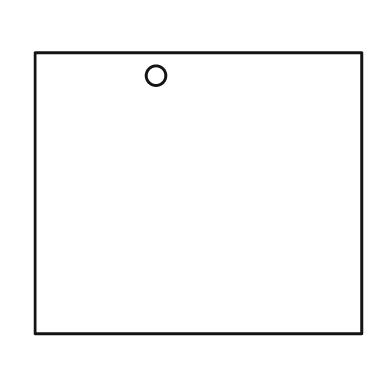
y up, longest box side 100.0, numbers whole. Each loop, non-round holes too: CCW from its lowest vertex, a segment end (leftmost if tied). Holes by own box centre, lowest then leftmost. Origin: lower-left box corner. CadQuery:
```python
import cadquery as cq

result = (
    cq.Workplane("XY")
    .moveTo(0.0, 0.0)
    .lineTo(100.0, 0.0)
    .lineTo(100.0, 86.0)
    .lineTo(0.0, 86.0)
    .close()
    .moveTo(37.0, 79.0)
    .circle(3.0)
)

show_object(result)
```